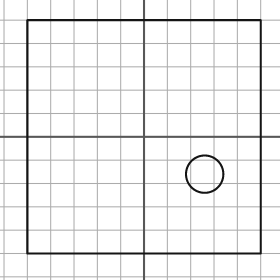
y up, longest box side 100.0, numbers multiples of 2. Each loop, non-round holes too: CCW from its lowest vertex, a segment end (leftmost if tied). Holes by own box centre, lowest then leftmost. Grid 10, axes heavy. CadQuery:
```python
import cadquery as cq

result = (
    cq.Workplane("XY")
    .moveTo(-50.0, -50.0)
    .lineTo(50.0, -50.0)
    .lineTo(50.0, 50.0)
    .lineTo(-50.0, 50.0)
    .close()
    .moveTo(26.0, -16.0)
    .circle(8.0)
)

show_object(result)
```